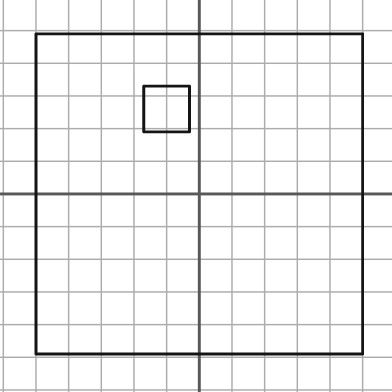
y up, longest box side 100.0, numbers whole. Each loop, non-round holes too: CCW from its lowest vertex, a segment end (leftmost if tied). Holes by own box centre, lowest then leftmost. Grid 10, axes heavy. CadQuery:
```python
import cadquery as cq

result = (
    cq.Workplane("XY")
    .moveTo(-50.0, -49.0)
    .lineTo(50.0, -49.0)
    .lineTo(50.0, 49.0)
    .lineTo(-50.0, 49.0)
    .close()
    .moveTo(-17.0, 19.0)
    .lineTo(-3.0, 19.0)
    .lineTo(-3.0, 33.0)
    .lineTo(-17.0, 33.0)
    .close()
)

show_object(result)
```